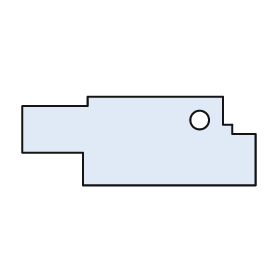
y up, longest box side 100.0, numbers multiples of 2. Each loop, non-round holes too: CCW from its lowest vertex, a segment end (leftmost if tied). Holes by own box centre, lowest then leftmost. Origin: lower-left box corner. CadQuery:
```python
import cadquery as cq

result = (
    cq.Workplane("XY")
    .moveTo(26.0, 0.0)
    .lineTo(100.0, 0.0)
    .lineTo(100.0, 22.0)
    .lineTo(90.0, 22.0)
    .lineTo(90.0, 26.0)
    .lineTo(86.0, 26.0)
    .lineTo(86.0, 38.0)
    .lineTo(28.0, 38.0)
    .lineTo(28.0, 34.0)
    .lineTo(0.0, 34.0)
    .lineTo(0.0, 14.0)
    .lineTo(26.0, 14.0)
    .close()
    .moveTo(76.0, 28.0)
    .circle(4.0)
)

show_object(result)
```